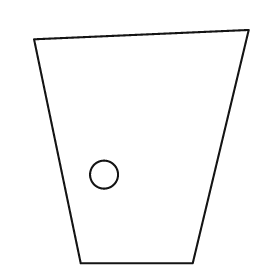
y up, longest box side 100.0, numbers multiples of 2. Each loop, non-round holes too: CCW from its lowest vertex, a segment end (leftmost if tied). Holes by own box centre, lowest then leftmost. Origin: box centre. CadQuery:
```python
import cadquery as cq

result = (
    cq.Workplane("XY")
    .moveTo(-26.0, -50.0)
    .lineTo(22.0, -50.0)
    .lineTo(46.0, 50.0)
    .lineTo(-46.0, 46.0)
    .close()
    .moveTo(-16.0, -12.0)
    .circle(6.0)
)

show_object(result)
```